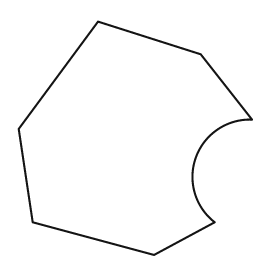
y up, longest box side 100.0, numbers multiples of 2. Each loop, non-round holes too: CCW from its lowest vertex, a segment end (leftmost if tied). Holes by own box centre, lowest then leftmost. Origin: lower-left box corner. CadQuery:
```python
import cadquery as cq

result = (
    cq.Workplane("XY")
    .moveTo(58.0, 0.0)
    .lineTo(84.0, 14.0)
    .threePointArc((76.0, 42.0), (100.0, 58.0))
    .lineTo(78.0, 86.0)
    .lineTo(34.0, 100.0)
    .lineTo(0.0, 54.0)
    .lineTo(6.0, 14.0)
    .close()
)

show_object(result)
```